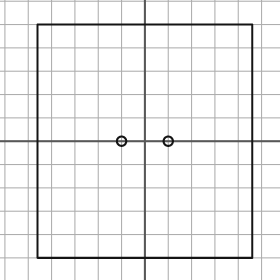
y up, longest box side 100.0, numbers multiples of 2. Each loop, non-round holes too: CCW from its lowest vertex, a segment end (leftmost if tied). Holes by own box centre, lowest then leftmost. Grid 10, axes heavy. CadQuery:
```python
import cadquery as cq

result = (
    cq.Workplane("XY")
    .moveTo(-46.0, -50.0)
    .lineTo(46.0, -50.0)
    .lineTo(46.0, 50.0)
    .lineTo(-46.0, 50.0)
    .close()
    .moveTo(-10.0, 0.0)
    .circle(2.0)
    .moveTo(10.0, 0.0)
    .circle(2.0)
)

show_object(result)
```